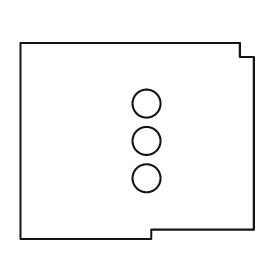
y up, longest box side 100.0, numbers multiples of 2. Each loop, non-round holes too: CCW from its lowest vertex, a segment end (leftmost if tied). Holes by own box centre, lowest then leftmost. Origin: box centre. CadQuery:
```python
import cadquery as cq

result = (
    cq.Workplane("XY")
    .moveTo(-50.0, -42.0)
    .lineTo(6.0, -42.0)
    .lineTo(6.0, -38.0)
    .lineTo(50.0, -38.0)
    .lineTo(50.0, 36.0)
    .lineTo(44.0, 36.0)
    .lineTo(44.0, 42.0)
    .lineTo(-50.0, 42.0)
    .close()
    .moveTo(4.0, -16.0)
    .circle(6.0)
    .moveTo(4.0, 0.0)
    .circle(6.0)
    .moveTo(4.0, 16.0)
    .circle(6.0)
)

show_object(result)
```